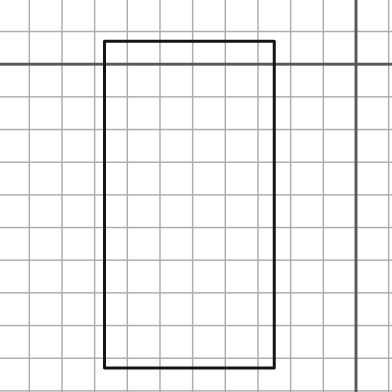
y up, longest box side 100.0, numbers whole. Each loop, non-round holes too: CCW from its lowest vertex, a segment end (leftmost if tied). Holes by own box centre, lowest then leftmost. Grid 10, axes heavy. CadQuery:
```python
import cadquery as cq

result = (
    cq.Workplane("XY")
    .moveTo(-77.0, -93.0)
    .lineTo(-25.0, -93.0)
    .lineTo(-25.0, 7.0)
    .lineTo(-77.0, 7.0)
    .close()
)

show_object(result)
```